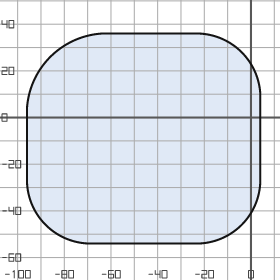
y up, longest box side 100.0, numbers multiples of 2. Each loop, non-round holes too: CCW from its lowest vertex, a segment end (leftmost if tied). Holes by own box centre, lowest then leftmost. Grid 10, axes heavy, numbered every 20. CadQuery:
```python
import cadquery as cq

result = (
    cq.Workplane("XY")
    .moveTo(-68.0, -54.0)
    .lineTo(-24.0, -54.0)
    .threePointArc((-4.0, -46.0), (4.0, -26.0))
    .lineTo(4.0, 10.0)
    .threePointArc((-4.0, 28.0), (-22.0, 36.0))
    .lineTo(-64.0, 36.0)
    .threePointArc((-86.0, 26.0), (-96.0, 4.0))
    .lineTo(-96.0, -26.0)
    .threePointArc((-88.0, -46.0), (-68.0, -54.0))
    .close()
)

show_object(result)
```